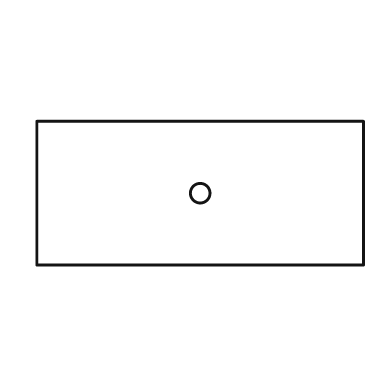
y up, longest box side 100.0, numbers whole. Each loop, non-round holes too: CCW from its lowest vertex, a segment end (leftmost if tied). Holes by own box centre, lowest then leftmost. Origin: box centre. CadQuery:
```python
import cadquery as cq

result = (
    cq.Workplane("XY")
    .moveTo(-50.0, -22.0)
    .lineTo(50.0, -22.0)
    .lineTo(50.0, 22.0)
    .lineTo(-50.0, 22.0)
    .close()
    .moveTo(0.0, 0.0)
    .circle(3.0)
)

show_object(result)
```